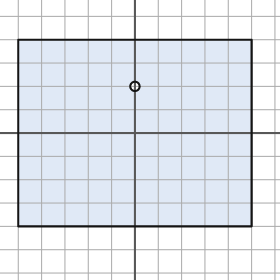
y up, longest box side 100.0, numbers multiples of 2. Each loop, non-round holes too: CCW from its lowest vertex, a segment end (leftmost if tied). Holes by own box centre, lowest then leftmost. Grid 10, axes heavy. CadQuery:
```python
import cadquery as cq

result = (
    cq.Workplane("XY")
    .moveTo(-50.0, -40.0)
    .lineTo(50.0, -40.0)
    .lineTo(50.0, 40.0)
    .lineTo(-50.0, 40.0)
    .close()
    .moveTo(0.0, 20.0)
    .circle(2.0)
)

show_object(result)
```